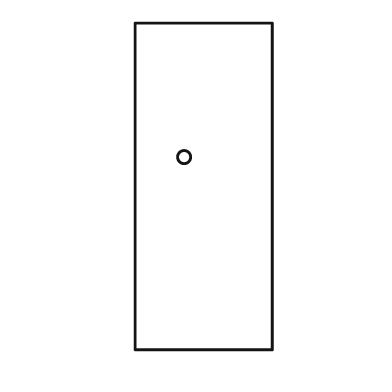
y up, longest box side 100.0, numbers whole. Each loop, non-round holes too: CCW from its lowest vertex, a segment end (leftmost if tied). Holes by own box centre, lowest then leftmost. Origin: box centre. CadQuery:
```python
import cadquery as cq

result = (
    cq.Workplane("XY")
    .moveTo(-21.0, -50.0)
    .lineTo(21.0, -50.0)
    .lineTo(21.0, 50.0)
    .lineTo(-21.0, 50.0)
    .close()
    .moveTo(-6.0, 9.0)
    .circle(2.0)
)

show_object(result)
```